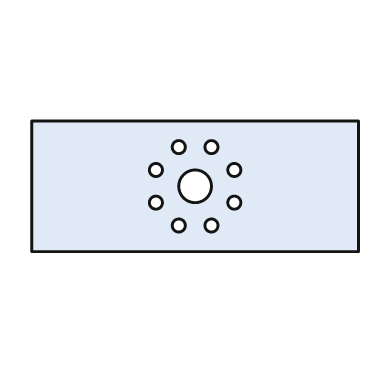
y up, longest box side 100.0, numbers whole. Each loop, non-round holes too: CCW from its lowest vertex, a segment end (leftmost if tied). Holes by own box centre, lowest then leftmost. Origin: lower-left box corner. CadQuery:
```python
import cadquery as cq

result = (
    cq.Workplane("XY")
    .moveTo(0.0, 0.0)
    .lineTo(100.0, 0.0)
    .lineTo(100.0, 40.0)
    .lineTo(0.0, 40.0)
    .close()
    .moveTo(45.0, 8.0)
    .circle(2.0)
    .moveTo(55.0, 8.0)
    .circle(2.0)
    .moveTo(38.0, 15.0)
    .circle(2.0)
    .moveTo(62.0, 15.0)
    .circle(2.0)
    .moveTo(50.0, 20.0)
    .circle(5.0)
    .moveTo(38.0, 25.0)
    .circle(2.0)
    .moveTo(62.0, 25.0)
    .circle(2.0)
    .moveTo(45.0, 32.0)
    .circle(2.0)
    .moveTo(55.0, 32.0)
    .circle(2.0)
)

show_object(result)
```